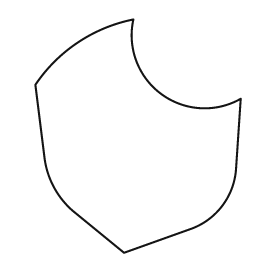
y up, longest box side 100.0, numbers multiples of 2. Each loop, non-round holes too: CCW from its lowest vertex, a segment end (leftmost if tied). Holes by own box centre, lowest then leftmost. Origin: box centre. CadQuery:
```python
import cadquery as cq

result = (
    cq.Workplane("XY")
    .moveTo(-6.0, -50.0)
    .lineTo(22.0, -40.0)
    .threePointArc((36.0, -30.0), (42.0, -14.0))
    .lineTo(44.0, 16.0)
    .threePointArc((10.0, 18.0), (-2.0, 50.0))
    .threePointArc((-26.0, 40.0), (-44.0, 22.0))
    .lineTo(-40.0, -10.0)
    .threePointArc((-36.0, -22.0), (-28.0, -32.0))
    .close()
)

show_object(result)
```